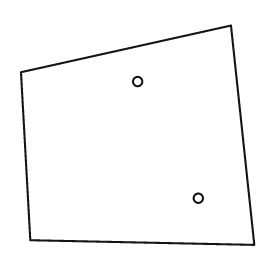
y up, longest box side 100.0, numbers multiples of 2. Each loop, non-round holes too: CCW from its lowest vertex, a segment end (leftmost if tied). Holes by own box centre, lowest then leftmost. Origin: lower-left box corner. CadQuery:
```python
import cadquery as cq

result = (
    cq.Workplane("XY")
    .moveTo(100.0, 0.0)
    .lineTo(90.0, 94.0)
    .lineTo(0.0, 74.0)
    .lineTo(4.0, 2.0)
    .close()
    .moveTo(76.0, 20.0)
    .circle(2.0)
    .moveTo(50.0, 70.0)
    .circle(2.0)
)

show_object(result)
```